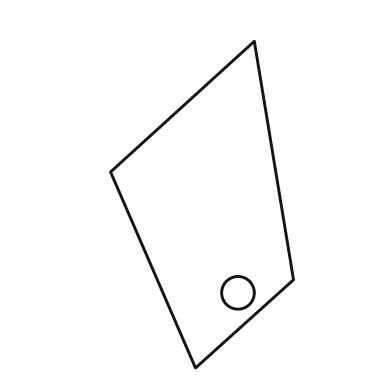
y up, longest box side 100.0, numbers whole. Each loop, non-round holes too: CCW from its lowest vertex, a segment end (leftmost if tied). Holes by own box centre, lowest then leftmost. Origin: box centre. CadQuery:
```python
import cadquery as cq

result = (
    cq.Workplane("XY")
    .moveTo(-2.0, -50.0)
    .lineTo(28.0, -23.0)
    .lineTo(16.0, 50.0)
    .lineTo(-28.0, 10.0)
    .close()
    .moveTo(11.0, -27.0)
    .circle(5.0)
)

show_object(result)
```